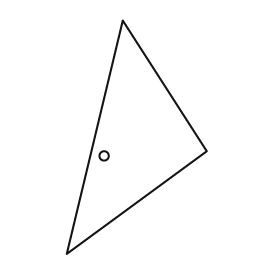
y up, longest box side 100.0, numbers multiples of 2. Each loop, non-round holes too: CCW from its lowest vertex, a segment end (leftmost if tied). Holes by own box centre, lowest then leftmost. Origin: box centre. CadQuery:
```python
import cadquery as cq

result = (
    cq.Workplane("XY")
    .moveTo(-30.0, -50.0)
    .lineTo(30.0, -6.0)
    .lineTo(-6.0, 50.0)
    .close()
    .moveTo(-14.0, -8.0)
    .circle(2.0)
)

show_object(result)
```